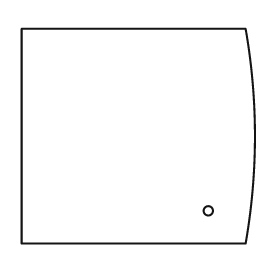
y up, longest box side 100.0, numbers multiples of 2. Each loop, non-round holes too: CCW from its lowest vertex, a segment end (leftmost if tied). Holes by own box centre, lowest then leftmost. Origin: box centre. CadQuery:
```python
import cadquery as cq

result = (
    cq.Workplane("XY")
    .moveTo(-50.0, -46.0)
    .lineTo(46.0, -46.0)
    .threePointArc((50.0, 0.0), (46.0, 46.0))
    .lineTo(-50.0, 46.0)
    .close()
    .moveTo(30.0, -32.0)
    .circle(2.0)
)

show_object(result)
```